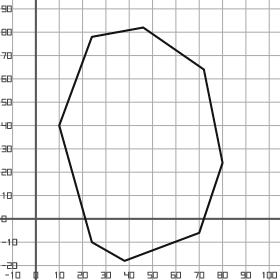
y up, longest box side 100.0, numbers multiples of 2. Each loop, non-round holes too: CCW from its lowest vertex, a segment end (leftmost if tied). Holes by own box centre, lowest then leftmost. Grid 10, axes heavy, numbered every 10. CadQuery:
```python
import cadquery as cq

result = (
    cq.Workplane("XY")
    .moveTo(38.0, -18.0)
    .lineTo(70.0, -6.0)
    .lineTo(80.0, 24.0)
    .lineTo(72.0, 64.0)
    .lineTo(46.0, 82.0)
    .lineTo(24.0, 78.0)
    .lineTo(10.0, 40.0)
    .lineTo(24.0, -10.0)
    .close()
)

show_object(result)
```